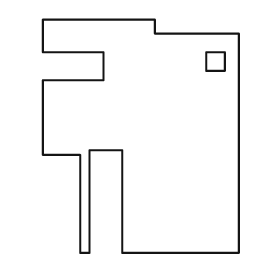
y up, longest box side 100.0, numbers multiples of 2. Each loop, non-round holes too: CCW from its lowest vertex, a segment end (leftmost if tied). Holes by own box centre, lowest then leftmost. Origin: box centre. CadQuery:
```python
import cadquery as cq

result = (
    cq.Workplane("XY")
    .moveTo(-26.0, -50.0)
    .lineTo(-22.0, -50.0)
    .lineTo(-22.0, -6.0)
    .lineTo(-8.0, -6.0)
    .lineTo(-8.0, -50.0)
    .lineTo(42.0, -50.0)
    .lineTo(42.0, 44.0)
    .lineTo(6.0, 44.0)
    .lineTo(6.0, 50.0)
    .lineTo(-42.0, 50.0)
    .lineTo(-42.0, 36.0)
    .lineTo(-16.0, 36.0)
    .lineTo(-16.0, 24.0)
    .lineTo(-42.0, 24.0)
    .lineTo(-42.0, -8.0)
    .lineTo(-26.0, -8.0)
    .close()
    .moveTo(28.0, 28.0)
    .lineTo(36.0, 28.0)
    .lineTo(36.0, 36.0)
    .lineTo(28.0, 36.0)
    .close()
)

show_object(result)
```